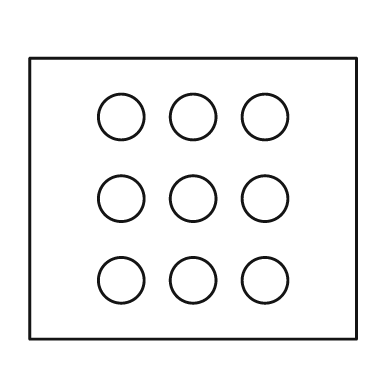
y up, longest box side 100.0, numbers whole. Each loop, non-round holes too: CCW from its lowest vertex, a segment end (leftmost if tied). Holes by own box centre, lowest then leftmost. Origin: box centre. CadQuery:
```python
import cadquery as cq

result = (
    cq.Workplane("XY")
    .moveTo(-50.0, -43.0)
    .lineTo(50.0, -43.0)
    .lineTo(50.0, 43.0)
    .lineTo(-50.0, 43.0)
    .close()
    .moveTo(-22.0, -25.0)
    .circle(7.0)
    .moveTo(0.0, -25.0)
    .circle(7.0)
    .moveTo(22.0, -25.0)
    .circle(7.0)
    .moveTo(-22.0, 0.0)
    .circle(7.0)
    .moveTo(0.0, 0.0)
    .circle(7.0)
    .moveTo(22.0, 0.0)
    .circle(7.0)
    .moveTo(-22.0, 25.0)
    .circle(7.0)
    .moveTo(0.0, 25.0)
    .circle(7.0)
    .moveTo(22.0, 25.0)
    .circle(7.0)
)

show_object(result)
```